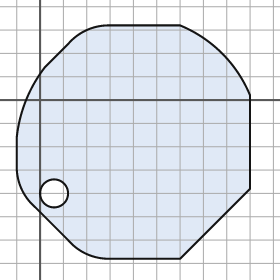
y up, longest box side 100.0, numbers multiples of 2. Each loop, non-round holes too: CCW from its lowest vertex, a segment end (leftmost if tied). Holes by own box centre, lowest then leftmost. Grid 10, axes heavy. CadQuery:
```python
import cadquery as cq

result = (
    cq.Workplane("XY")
    .moveTo(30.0, -68.0)
    .lineTo(60.0, -68.0)
    .lineTo(90.0, -38.0)
    .lineTo(90.0, 2.0)
    .threePointArc((78.0, 20.0), (60.0, 32.0))
    .lineTo(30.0, 32.0)
    .threePointArc((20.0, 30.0), (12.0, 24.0))
    .lineTo(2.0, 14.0)
    .threePointArc((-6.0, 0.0), (-10.0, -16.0))
    .lineTo(-10.0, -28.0)
    .threePointArc((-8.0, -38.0), (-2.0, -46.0))
    .lineTo(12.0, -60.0)
    .threePointArc((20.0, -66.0), (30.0, -68.0))
    .close()
    .moveTo(6.0, -40.0)
    .circle(6.0)
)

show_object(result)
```